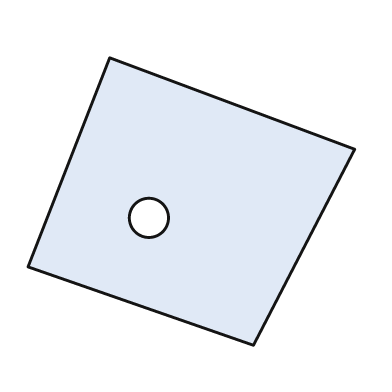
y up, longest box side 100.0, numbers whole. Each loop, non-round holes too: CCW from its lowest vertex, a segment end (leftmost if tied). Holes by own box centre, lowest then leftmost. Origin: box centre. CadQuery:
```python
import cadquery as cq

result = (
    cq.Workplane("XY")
    .moveTo(19.0, -44.0)
    .lineTo(50.0, 16.0)
    .lineTo(-25.0, 44.0)
    .lineTo(-50.0, -20.0)
    .close()
    .moveTo(-13.0, -5.0)
    .circle(6.0)
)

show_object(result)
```